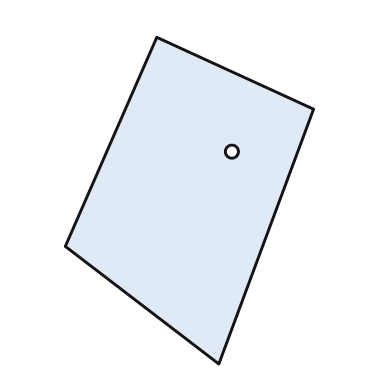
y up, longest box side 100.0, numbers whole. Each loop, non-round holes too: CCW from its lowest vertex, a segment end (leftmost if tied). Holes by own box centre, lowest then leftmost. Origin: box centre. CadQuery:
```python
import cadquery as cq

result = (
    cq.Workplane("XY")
    .moveTo(9.0, -50.0)
    .lineTo(38.0, 28.0)
    .lineTo(-10.0, 50.0)
    .lineTo(-38.0, -14.0)
    .close()
    .moveTo(13.0, 15.0)
    .circle(2.0)
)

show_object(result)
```